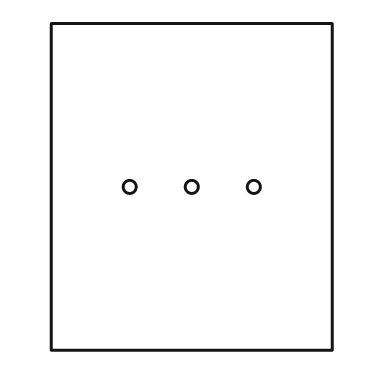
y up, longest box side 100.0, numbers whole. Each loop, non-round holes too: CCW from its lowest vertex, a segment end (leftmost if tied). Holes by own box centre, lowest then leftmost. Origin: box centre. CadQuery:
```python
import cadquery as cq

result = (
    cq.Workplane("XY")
    .moveTo(-43.0, -50.0)
    .lineTo(43.0, -50.0)
    .lineTo(43.0, 50.0)
    .lineTo(-43.0, 50.0)
    .close()
    .moveTo(-19.0, 0.0)
    .circle(2.0)
    .moveTo(0.0, 0.0)
    .circle(2.0)
    .moveTo(19.0, 0.0)
    .circle(2.0)
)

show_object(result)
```